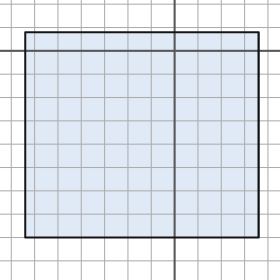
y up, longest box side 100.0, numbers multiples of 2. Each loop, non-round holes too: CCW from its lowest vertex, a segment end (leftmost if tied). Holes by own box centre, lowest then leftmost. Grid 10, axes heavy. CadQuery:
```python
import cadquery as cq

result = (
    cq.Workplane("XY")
    .moveTo(-64.0, -80.0)
    .lineTo(36.0, -80.0)
    .lineTo(36.0, 8.0)
    .lineTo(-64.0, 8.0)
    .close()
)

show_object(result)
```